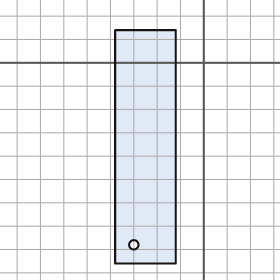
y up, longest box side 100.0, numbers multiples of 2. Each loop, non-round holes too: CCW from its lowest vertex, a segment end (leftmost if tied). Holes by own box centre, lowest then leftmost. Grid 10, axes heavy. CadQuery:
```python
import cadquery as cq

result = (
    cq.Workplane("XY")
    .moveTo(-38.0, -86.0)
    .lineTo(-12.0, -86.0)
    .lineTo(-12.0, 14.0)
    .lineTo(-38.0, 14.0)
    .close()
    .moveTo(-30.0, -78.0)
    .circle(2.0)
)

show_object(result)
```